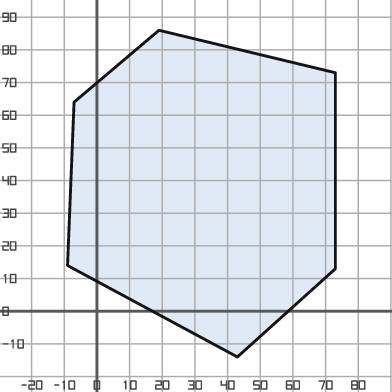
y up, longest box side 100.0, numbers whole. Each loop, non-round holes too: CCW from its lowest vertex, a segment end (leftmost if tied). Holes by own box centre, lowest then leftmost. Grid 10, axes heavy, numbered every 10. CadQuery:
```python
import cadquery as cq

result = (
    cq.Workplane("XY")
    .moveTo(43.0, -14.0)
    .lineTo(73.0, 13.0)
    .lineTo(73.0, 73.0)
    .lineTo(19.0, 86.0)
    .lineTo(-7.0, 64.0)
    .lineTo(-9.0, 14.0)
    .close()
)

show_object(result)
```